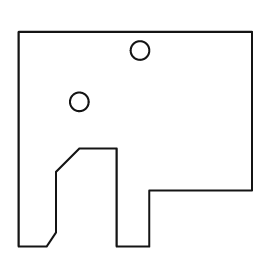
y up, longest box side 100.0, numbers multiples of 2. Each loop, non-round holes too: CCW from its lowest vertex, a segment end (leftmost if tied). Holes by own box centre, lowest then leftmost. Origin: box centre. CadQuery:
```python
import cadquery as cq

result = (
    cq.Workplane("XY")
    .moveTo(-50.0, -46.0)
    .lineTo(-38.0, -46.0)
    .lineTo(-34.0, -40.0)
    .lineTo(-34.0, -14.0)
    .lineTo(-24.0, -4.0)
    .lineTo(-8.0, -4.0)
    .lineTo(-8.0, -46.0)
    .lineTo(6.0, -46.0)
    .lineTo(6.0, -22.0)
    .lineTo(50.0, -22.0)
    .lineTo(50.0, 46.0)
    .lineTo(-50.0, 46.0)
    .close()
    .moveTo(-24.0, 16.0)
    .circle(4.0)
    .moveTo(2.0, 38.0)
    .circle(4.0)
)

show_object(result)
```